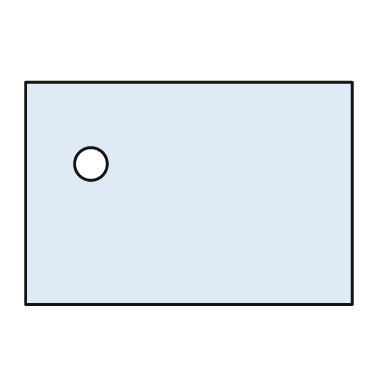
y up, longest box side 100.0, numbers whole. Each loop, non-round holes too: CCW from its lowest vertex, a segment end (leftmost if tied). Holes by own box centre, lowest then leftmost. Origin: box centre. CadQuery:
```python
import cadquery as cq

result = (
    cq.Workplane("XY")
    .moveTo(-50.0, -34.0)
    .lineTo(50.0, -34.0)
    .lineTo(50.0, 34.0)
    .lineTo(-50.0, 34.0)
    .close()
    .moveTo(-30.0, 9.0)
    .circle(5.0)
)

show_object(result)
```